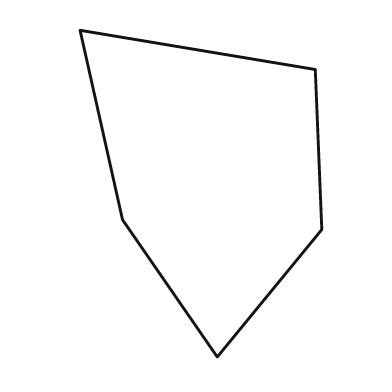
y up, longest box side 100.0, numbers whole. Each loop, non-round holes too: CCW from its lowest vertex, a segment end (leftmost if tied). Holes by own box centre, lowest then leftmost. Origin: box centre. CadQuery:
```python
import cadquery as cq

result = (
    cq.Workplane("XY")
    .moveTo(5.0, -50.0)
    .lineTo(37.0, -11.0)
    .lineTo(35.0, 38.0)
    .lineTo(-37.0, 50.0)
    .lineTo(-24.0, -8.0)
    .close()
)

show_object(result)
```